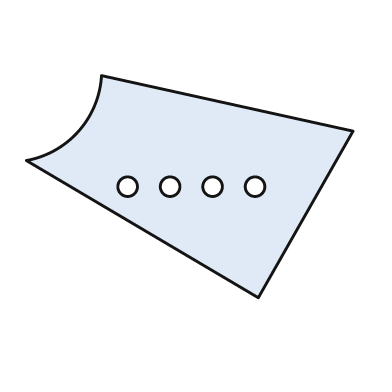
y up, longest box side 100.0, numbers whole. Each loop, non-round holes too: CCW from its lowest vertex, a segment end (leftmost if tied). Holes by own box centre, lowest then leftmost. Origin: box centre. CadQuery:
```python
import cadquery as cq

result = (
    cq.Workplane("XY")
    .moveTo(21.0, -34.0)
    .lineTo(50.0, 17.0)
    .lineTo(-27.0, 34.0)
    .threePointArc((-34.0, 17.0), (-50.0, 8.0))
    .close()
    .moveTo(-19.0, 0.0)
    .circle(3.0)
    .moveTo(-6.0, 0.0)
    .circle(3.0)
    .moveTo(7.0, 0.0)
    .circle(3.0)
    .moveTo(20.0, 0.0)
    .circle(3.0)
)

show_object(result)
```